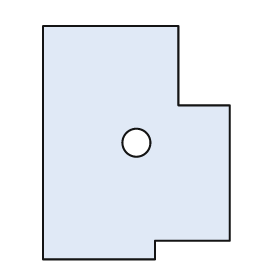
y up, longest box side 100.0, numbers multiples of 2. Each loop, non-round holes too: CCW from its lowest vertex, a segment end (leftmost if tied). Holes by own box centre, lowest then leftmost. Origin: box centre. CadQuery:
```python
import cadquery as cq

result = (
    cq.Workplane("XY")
    .moveTo(-40.0, -50.0)
    .lineTo(8.0, -50.0)
    .lineTo(8.0, -42.0)
    .lineTo(40.0, -42.0)
    .lineTo(40.0, 16.0)
    .lineTo(18.0, 16.0)
    .lineTo(18.0, 50.0)
    .lineTo(-40.0, 50.0)
    .close()
    .moveTo(0.0, 0.0)
    .circle(6.0)
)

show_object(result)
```